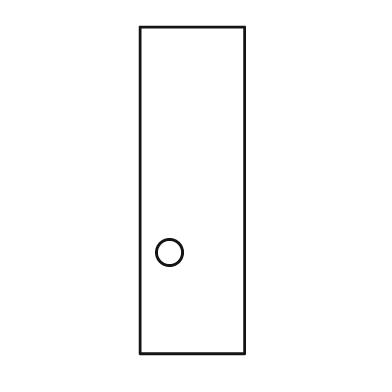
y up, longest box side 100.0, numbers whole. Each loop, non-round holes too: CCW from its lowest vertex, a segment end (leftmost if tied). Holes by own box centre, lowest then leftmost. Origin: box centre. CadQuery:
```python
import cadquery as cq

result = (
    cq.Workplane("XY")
    .moveTo(-16.0, -50.0)
    .lineTo(16.0, -50.0)
    .lineTo(16.0, 50.0)
    .lineTo(-16.0, 50.0)
    .close()
    .moveTo(-7.0, -19.0)
    .circle(4.0)
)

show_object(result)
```